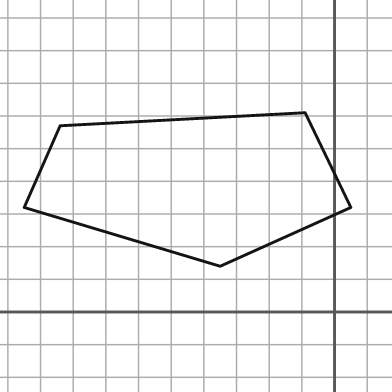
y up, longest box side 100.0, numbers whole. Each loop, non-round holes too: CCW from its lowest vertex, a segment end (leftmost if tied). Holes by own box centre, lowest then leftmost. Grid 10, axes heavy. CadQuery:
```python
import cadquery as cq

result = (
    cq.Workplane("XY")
    .moveTo(-35.0, 14.0)
    .lineTo(5.0, 32.0)
    .lineTo(-9.0, 61.0)
    .lineTo(-84.0, 57.0)
    .lineTo(-95.0, 32.0)
    .close()
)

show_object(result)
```